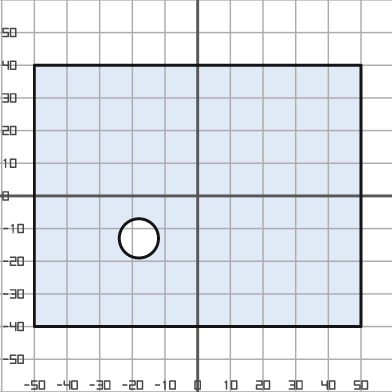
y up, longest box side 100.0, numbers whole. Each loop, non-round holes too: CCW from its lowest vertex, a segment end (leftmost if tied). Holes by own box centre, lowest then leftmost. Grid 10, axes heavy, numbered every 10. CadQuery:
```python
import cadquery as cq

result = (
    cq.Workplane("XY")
    .moveTo(-50.0, -40.0)
    .lineTo(50.0, -40.0)
    .lineTo(50.0, 40.0)
    .lineTo(-50.0, 40.0)
    .close()
    .moveTo(-18.0, -13.0)
    .circle(6.0)
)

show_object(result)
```